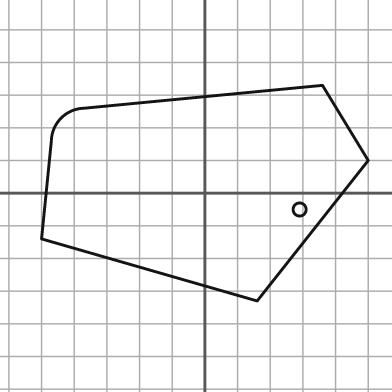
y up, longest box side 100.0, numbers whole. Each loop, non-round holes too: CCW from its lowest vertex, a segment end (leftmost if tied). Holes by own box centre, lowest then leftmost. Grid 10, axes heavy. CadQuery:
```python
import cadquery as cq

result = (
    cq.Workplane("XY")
    .moveTo(16.0, -33.0)
    .lineTo(50.0, 10.0)
    .lineTo(36.0, 33.0)
    .lineTo(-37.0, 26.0)
    .threePointArc((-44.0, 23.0), (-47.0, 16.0))
    .lineTo(-50.0, -14.0)
    .close()
    .moveTo(29.0, -5.0)
    .circle(2.0)
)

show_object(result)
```